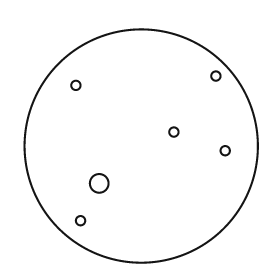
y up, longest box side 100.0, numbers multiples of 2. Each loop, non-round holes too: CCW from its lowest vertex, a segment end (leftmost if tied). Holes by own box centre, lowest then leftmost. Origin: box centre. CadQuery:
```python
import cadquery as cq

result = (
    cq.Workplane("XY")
    .moveTo(0.0, 0.0)
    .circle(50.0)
    .moveTo(-26.0, -32.0)
    .circle(2.0)
    .moveTo(-18.0, -16.0)
    .circle(4.0)
    .moveTo(36.0, -2.0)
    .circle(2.0)
    .moveTo(14.0, 6.0)
    .circle(2.0)
    .moveTo(-28.0, 26.0)
    .circle(2.0)
    .moveTo(32.0, 30.0)
    .circle(2.0)
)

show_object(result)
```